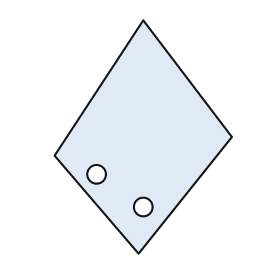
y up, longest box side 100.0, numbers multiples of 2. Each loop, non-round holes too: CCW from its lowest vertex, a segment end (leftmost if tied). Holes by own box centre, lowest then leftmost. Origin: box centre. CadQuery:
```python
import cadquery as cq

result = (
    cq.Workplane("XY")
    .moveTo(-2.0, -50.0)
    .lineTo(38.0, 0.0)
    .lineTo(0.0, 50.0)
    .lineTo(-38.0, -8.0)
    .close()
    .moveTo(0.0, -30.0)
    .circle(4.0)
    .moveTo(-20.0, -16.0)
    .circle(4.0)
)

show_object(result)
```